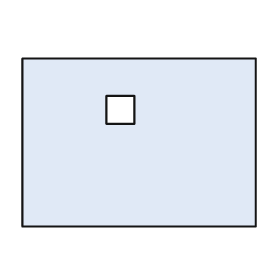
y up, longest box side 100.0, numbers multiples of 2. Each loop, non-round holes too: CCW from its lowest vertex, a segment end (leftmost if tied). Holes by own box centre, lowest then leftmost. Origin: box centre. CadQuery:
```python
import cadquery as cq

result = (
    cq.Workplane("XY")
    .moveTo(-50.0, -36.0)
    .lineTo(50.0, -36.0)
    .lineTo(50.0, 36.0)
    .lineTo(-50.0, 36.0)
    .close()
    .moveTo(-14.0, 8.0)
    .lineTo(-2.0, 8.0)
    .lineTo(-2.0, 20.0)
    .lineTo(-14.0, 20.0)
    .close()
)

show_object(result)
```